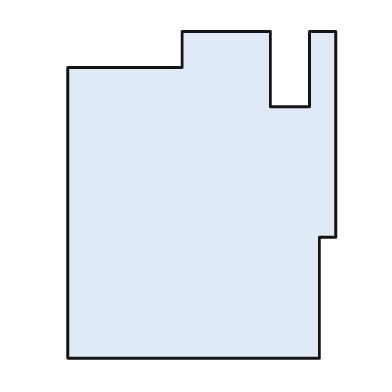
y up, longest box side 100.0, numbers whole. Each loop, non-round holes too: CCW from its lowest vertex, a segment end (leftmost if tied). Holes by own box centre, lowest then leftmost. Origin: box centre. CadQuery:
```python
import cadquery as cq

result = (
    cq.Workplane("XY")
    .moveTo(-41.0, -50.0)
    .lineTo(36.0, -50.0)
    .lineTo(36.0, -13.0)
    .lineTo(41.0, -13.0)
    .lineTo(41.0, 50.0)
    .lineTo(33.0, 50.0)
    .lineTo(33.0, 27.0)
    .lineTo(21.0, 27.0)
    .lineTo(21.0, 50.0)
    .lineTo(-6.0, 50.0)
    .lineTo(-6.0, 39.0)
    .lineTo(-41.0, 39.0)
    .close()
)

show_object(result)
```